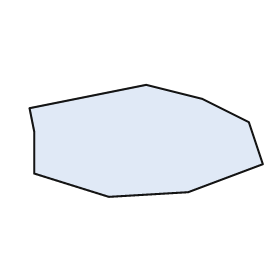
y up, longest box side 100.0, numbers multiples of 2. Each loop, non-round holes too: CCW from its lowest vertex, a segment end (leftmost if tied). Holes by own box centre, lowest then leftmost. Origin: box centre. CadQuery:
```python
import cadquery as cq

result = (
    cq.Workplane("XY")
    .moveTo(-16.0, -24.0)
    .lineTo(18.0, -22.0)
    .lineTo(50.0, -10.0)
    .lineTo(44.0, 8.0)
    .lineTo(24.0, 18.0)
    .lineTo(0.0, 24.0)
    .lineTo(-50.0, 14.0)
    .lineTo(-48.0, 4.0)
    .lineTo(-48.0, -14.0)
    .close()
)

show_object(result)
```